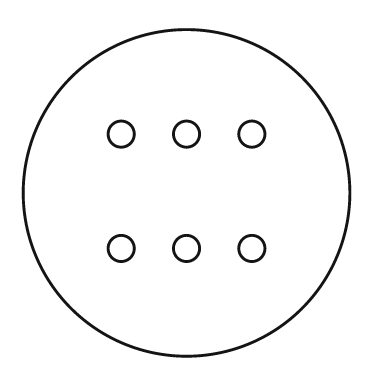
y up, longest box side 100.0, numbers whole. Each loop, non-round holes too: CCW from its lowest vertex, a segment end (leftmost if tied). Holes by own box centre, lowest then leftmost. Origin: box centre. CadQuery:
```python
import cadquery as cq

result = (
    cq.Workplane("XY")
    .moveTo(0.0, 0.0)
    .circle(50.0)
    .moveTo(-20.0, -17.0)
    .circle(4.0)
    .moveTo(0.0, -17.0)
    .circle(4.0)
    .moveTo(20.0, -17.0)
    .circle(4.0)
    .moveTo(-20.0, 18.0)
    .circle(4.0)
    .moveTo(0.0, 18.0)
    .circle(4.0)
    .moveTo(20.0, 18.0)
    .circle(4.0)
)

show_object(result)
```